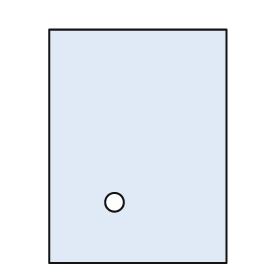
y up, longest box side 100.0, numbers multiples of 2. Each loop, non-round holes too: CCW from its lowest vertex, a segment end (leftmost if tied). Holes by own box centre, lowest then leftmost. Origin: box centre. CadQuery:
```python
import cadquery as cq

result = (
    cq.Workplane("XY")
    .moveTo(-38.0, -50.0)
    .lineTo(38.0, -50.0)
    .lineTo(38.0, 50.0)
    .lineTo(-38.0, 50.0)
    .close()
    .moveTo(-10.0, -24.0)
    .circle(4.0)
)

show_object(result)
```